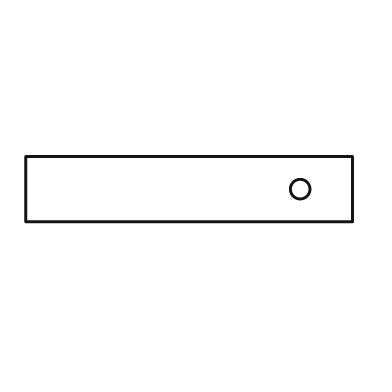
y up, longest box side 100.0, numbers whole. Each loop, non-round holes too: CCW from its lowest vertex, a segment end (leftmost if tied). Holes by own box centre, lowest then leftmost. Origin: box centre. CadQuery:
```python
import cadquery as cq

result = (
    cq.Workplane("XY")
    .moveTo(-50.0, -10.0)
    .lineTo(50.0, -10.0)
    .lineTo(50.0, 10.0)
    .lineTo(-50.0, 10.0)
    .close()
    .moveTo(34.0, 0.0)
    .circle(3.0)
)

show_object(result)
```